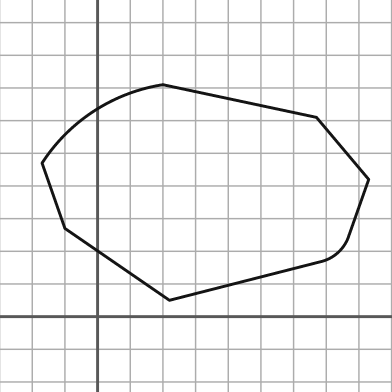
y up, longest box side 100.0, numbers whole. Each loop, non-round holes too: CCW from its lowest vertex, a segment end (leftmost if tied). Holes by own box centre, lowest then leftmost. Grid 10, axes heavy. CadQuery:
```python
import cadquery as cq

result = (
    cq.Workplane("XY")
    .moveTo(22.0, 5.0)
    .lineTo(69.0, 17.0)
    .threePointArc((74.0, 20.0), (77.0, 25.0))
    .lineTo(83.0, 42.0)
    .lineTo(67.0, 61.0)
    .lineTo(20.0, 71.0)
    .threePointArc((-1.0, 63.0), (-17.0, 47.0))
    .lineTo(-10.0, 27.0)
    .close()
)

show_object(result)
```